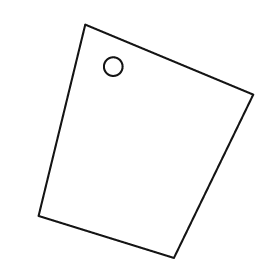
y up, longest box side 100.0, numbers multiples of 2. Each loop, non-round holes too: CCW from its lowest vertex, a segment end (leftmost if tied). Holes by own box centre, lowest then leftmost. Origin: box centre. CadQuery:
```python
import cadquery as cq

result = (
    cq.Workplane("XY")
    .moveTo(12.0, -50.0)
    .lineTo(46.0, 20.0)
    .lineTo(-26.0, 50.0)
    .lineTo(-46.0, -32.0)
    .close()
    .moveTo(-14.0, 32.0)
    .circle(4.0)
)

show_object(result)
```